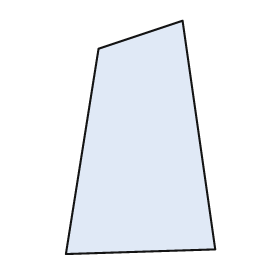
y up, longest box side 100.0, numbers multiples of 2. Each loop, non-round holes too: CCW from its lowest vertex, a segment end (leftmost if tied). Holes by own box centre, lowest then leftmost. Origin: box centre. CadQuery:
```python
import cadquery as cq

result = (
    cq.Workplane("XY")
    .moveTo(-32.0, -50.0)
    .lineTo(32.0, -48.0)
    .lineTo(18.0, 50.0)
    .lineTo(-18.0, 38.0)
    .close()
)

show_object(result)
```